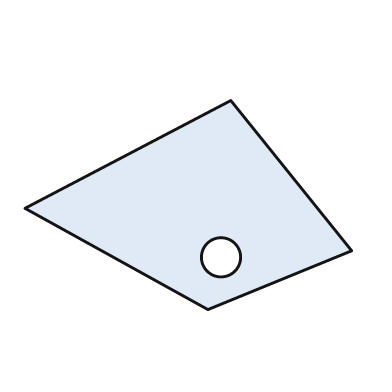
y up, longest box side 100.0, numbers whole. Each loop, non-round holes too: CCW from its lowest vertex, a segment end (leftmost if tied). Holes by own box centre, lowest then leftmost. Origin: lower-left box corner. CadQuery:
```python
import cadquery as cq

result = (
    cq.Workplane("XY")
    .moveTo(56.0, 0.0)
    .lineTo(100.0, 18.0)
    .lineTo(63.0, 64.0)
    .lineTo(0.0, 31.0)
    .close()
    .moveTo(60.0, 16.0)
    .circle(6.0)
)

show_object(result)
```